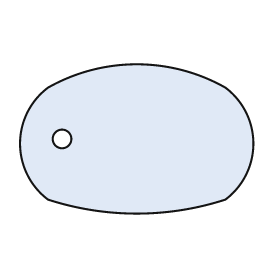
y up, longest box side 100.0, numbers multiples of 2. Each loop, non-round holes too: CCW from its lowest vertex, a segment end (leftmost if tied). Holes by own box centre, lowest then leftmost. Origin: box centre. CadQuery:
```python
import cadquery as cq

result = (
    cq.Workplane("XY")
    .moveTo(-38.0, -26.0)
    .threePointArc((0.0, -32.0), (38.0, -26.0))
    .threePointArc((50.0, -2.0), (38.0, 22.0))
    .threePointArc((0.0, 32.0), (-38.0, 22.0))
    .threePointArc((-50.0, -2.0), (-38.0, -26.0))
    .close()
    .moveTo(-32.0, 0.0)
    .circle(4.0)
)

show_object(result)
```